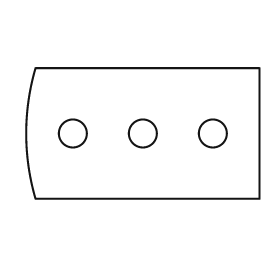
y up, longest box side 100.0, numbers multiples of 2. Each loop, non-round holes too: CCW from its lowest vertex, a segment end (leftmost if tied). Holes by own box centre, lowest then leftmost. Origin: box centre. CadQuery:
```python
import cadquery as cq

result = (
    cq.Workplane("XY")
    .moveTo(-46.0, -28.0)
    .lineTo(50.0, -28.0)
    .lineTo(50.0, 28.0)
    .lineTo(-46.0, 28.0)
    .threePointArc((-50.0, 0.0), (-46.0, -28.0))
    .close()
    .moveTo(-30.0, 0.0)
    .circle(6.0)
    .moveTo(0.0, 0.0)
    .circle(6.0)
    .moveTo(30.0, 0.0)
    .circle(6.0)
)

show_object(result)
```